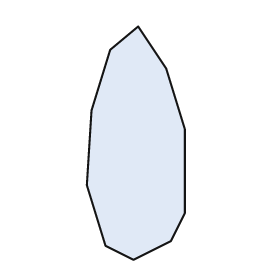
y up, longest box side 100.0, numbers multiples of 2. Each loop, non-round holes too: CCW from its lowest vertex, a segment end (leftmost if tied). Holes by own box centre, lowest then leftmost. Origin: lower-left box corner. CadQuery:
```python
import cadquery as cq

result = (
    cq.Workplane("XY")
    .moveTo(20.0, 0.0)
    .lineTo(36.0, 8.0)
    .lineTo(42.0, 20.0)
    .lineTo(42.0, 56.0)
    .lineTo(34.0, 82.0)
    .lineTo(22.0, 100.0)
    .lineTo(10.0, 90.0)
    .lineTo(2.0, 64.0)
    .lineTo(0.0, 32.0)
    .lineTo(8.0, 6.0)
    .close()
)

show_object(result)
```